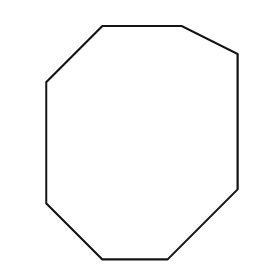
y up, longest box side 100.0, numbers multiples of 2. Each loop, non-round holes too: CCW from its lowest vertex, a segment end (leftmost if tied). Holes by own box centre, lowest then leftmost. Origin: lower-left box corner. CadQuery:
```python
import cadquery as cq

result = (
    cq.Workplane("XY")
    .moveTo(24.0, 0.0)
    .lineTo(52.0, 0.0)
    .lineTo(82.0, 30.0)
    .lineTo(82.0, 88.0)
    .lineTo(58.0, 100.0)
    .lineTo(24.0, 100.0)
    .lineTo(0.0, 76.0)
    .lineTo(0.0, 24.0)
    .close()
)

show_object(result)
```